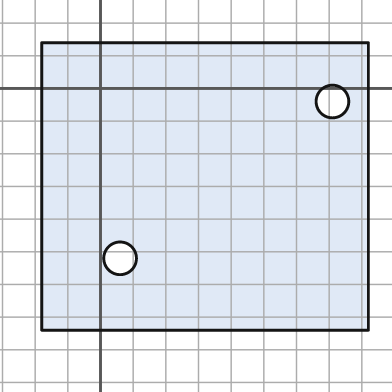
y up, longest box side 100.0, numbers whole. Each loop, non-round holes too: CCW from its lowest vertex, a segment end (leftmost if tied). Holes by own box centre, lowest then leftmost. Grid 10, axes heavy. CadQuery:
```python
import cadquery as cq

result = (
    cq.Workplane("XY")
    .moveTo(-18.0, -74.0)
    .lineTo(82.0, -74.0)
    .lineTo(82.0, 14.0)
    .lineTo(-18.0, 14.0)
    .close()
    .moveTo(6.0, -52.0)
    .circle(5.0)
    .moveTo(71.0, -4.0)
    .circle(5.0)
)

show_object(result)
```